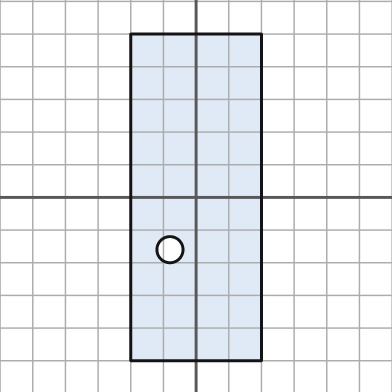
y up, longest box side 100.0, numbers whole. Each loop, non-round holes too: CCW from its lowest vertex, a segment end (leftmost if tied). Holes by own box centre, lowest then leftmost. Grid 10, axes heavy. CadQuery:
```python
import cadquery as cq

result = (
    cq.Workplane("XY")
    .moveTo(-20.0, -50.0)
    .lineTo(20.0, -50.0)
    .lineTo(20.0, 50.0)
    .lineTo(-20.0, 50.0)
    .close()
    .moveTo(-8.0, -16.0)
    .circle(4.0)
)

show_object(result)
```